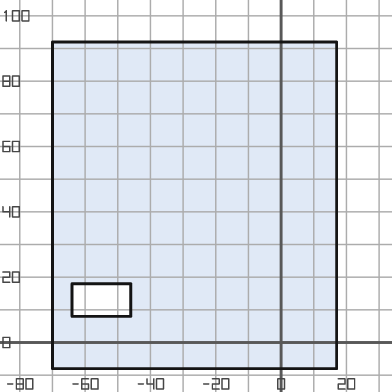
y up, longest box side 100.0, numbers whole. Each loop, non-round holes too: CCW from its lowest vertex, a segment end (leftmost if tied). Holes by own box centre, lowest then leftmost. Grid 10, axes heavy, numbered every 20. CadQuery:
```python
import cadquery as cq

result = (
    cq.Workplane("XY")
    .moveTo(-70.0, -8.0)
    .lineTo(17.0, -8.0)
    .lineTo(17.0, 92.0)
    .lineTo(-70.0, 92.0)
    .close()
    .moveTo(-64.0, 8.0)
    .lineTo(-46.0, 8.0)
    .lineTo(-46.0, 18.0)
    .lineTo(-64.0, 18.0)
    .close()
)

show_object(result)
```